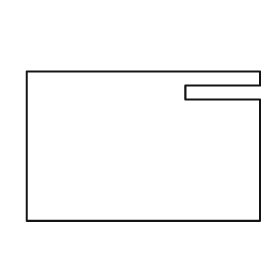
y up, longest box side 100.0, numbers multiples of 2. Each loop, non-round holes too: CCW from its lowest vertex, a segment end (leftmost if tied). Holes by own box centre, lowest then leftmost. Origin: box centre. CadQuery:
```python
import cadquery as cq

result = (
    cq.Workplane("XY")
    .moveTo(-50.0, -32.0)
    .lineTo(50.0, -32.0)
    .lineTo(50.0, 20.0)
    .lineTo(18.0, 20.0)
    .lineTo(18.0, 26.0)
    .lineTo(50.0, 26.0)
    .lineTo(50.0, 32.0)
    .lineTo(-50.0, 32.0)
    .close()
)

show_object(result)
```